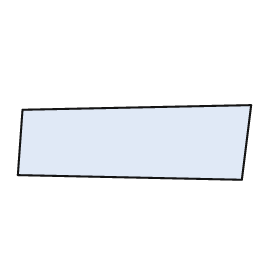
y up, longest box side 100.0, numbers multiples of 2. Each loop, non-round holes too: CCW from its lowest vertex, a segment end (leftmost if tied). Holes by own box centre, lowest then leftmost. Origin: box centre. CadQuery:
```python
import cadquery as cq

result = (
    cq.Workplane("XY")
    .moveTo(46.0, -16.0)
    .lineTo(50.0, 16.0)
    .lineTo(-48.0, 14.0)
    .lineTo(-50.0, -14.0)
    .close()
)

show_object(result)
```